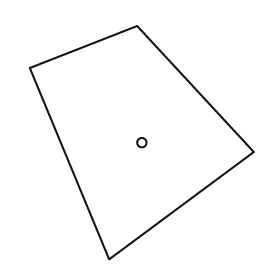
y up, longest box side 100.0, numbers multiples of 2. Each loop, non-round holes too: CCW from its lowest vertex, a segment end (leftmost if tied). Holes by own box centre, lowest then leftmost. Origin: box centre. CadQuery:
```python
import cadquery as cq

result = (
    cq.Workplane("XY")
    .moveTo(-14.0, -50.0)
    .lineTo(48.0, -4.0)
    .lineTo(-2.0, 50.0)
    .lineTo(-48.0, 32.0)
    .close()
    .moveTo(0.0, 0.0)
    .circle(2.0)
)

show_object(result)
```